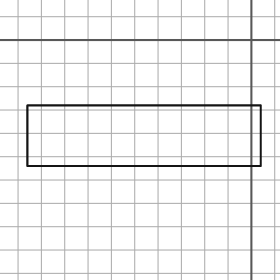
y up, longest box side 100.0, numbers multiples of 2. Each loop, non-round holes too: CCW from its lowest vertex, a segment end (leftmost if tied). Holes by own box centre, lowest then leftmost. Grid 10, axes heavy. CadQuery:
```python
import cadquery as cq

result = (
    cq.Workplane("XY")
    .moveTo(-96.0, -54.0)
    .lineTo(4.0, -54.0)
    .lineTo(4.0, -28.0)
    .lineTo(-96.0, -28.0)
    .close()
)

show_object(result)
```